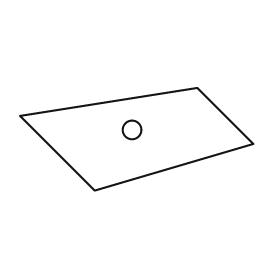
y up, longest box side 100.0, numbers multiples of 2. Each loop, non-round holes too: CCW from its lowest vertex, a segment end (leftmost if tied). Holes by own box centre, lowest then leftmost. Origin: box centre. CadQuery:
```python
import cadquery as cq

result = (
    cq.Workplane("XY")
    .moveTo(-18.0, -22.0)
    .lineTo(50.0, -2.0)
    .lineTo(26.0, 22.0)
    .lineTo(-50.0, 10.0)
    .close()
    .moveTo(-2.0, 4.0)
    .circle(4.0)
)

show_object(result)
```